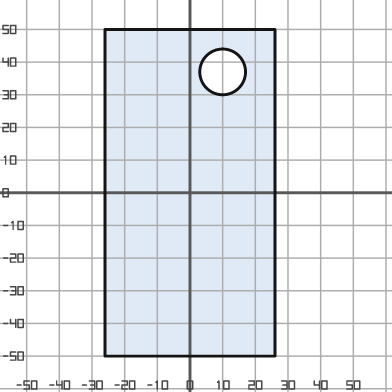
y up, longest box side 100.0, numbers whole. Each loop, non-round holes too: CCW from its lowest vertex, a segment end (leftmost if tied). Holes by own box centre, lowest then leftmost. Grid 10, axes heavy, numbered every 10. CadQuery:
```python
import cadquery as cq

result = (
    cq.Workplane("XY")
    .moveTo(-26.0, -50.0)
    .lineTo(26.0, -50.0)
    .lineTo(26.0, 50.0)
    .lineTo(-26.0, 50.0)
    .close()
    .moveTo(10.0, 37.0)
    .circle(7.0)
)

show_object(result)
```